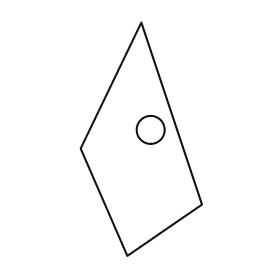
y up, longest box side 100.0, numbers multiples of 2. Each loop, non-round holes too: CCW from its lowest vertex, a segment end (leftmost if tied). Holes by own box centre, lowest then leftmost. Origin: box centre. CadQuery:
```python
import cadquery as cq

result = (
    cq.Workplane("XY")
    .moveTo(-6.0, -50.0)
    .lineTo(26.0, -28.0)
    .lineTo(0.0, 50.0)
    .lineTo(-26.0, -4.0)
    .close()
    .moveTo(4.0, 4.0)
    .circle(6.0)
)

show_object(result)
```